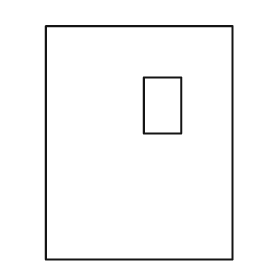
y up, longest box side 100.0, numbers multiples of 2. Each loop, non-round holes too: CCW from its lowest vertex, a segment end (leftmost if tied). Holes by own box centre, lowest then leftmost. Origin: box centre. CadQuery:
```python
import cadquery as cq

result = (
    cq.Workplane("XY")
    .moveTo(-40.0, -50.0)
    .lineTo(40.0, -50.0)
    .lineTo(40.0, 50.0)
    .lineTo(-40.0, 50.0)
    .close()
    .moveTo(2.0, 4.0)
    .lineTo(18.0, 4.0)
    .lineTo(18.0, 28.0)
    .lineTo(2.0, 28.0)
    .close()
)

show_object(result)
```